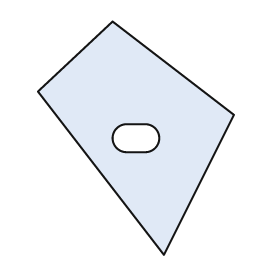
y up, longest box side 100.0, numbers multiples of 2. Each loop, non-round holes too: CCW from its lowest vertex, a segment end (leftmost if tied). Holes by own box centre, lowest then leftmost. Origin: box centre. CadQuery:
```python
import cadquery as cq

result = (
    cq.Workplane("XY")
    .moveTo(12.0, -50.0)
    .lineTo(42.0, 10.0)
    .lineTo(-10.0, 50.0)
    .lineTo(-42.0, 20.0)
    .close()
    .moveTo(-4.0, -6.0)
    .lineTo(4.0, -6.0)
    .threePointArc((10.0, 0.0), (4.0, 6.0))
    .lineTo(-4.0, 6.0)
    .threePointArc((-10.0, 0.0), (-4.0, -6.0))
    .close()
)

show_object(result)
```